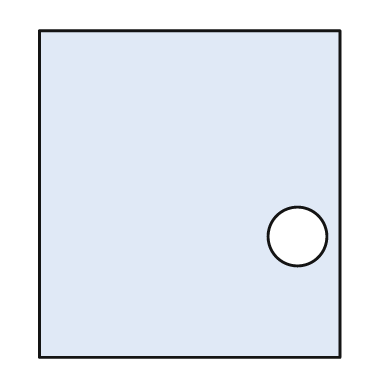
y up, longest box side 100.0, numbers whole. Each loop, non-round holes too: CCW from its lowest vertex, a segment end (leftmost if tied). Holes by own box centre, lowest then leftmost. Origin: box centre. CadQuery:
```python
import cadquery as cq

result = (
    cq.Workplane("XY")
    .moveTo(-46.0, -50.0)
    .lineTo(46.0, -50.0)
    .lineTo(46.0, 50.0)
    .lineTo(-46.0, 50.0)
    .close()
    .moveTo(33.0, -13.0)
    .circle(9.0)
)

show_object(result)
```